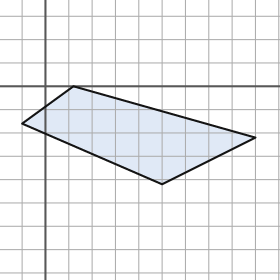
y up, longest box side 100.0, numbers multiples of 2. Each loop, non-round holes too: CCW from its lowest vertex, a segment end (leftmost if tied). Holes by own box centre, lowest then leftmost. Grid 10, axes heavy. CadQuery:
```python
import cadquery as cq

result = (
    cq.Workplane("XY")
    .moveTo(50.0, -42.0)
    .lineTo(90.0, -22.0)
    .lineTo(12.0, 0.0)
    .lineTo(-10.0, -16.0)
    .close()
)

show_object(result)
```